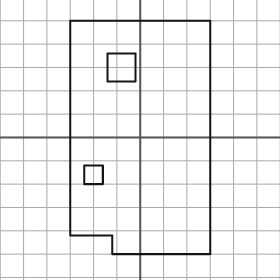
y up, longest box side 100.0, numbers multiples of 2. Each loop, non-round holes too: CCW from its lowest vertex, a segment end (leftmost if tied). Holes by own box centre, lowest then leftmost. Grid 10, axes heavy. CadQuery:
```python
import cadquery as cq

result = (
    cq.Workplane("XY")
    .moveTo(-12.0, -50.0)
    .lineTo(30.0, -50.0)
    .lineTo(30.0, 50.0)
    .lineTo(-30.0, 50.0)
    .lineTo(-30.0, -42.0)
    .lineTo(-12.0, -42.0)
    .close()
    .moveTo(-24.0, -20.0)
    .lineTo(-16.0, -20.0)
    .lineTo(-16.0, -12.0)
    .lineTo(-24.0, -12.0)
    .close()
    .moveTo(-14.0, 24.0)
    .lineTo(-2.0, 24.0)
    .lineTo(-2.0, 36.0)
    .lineTo(-14.0, 36.0)
    .close()
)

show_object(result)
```